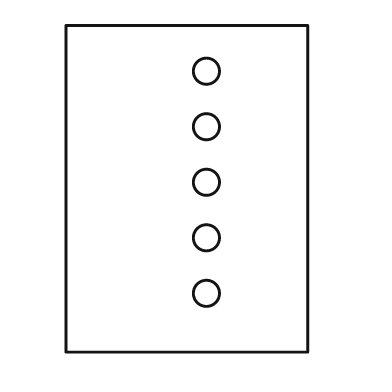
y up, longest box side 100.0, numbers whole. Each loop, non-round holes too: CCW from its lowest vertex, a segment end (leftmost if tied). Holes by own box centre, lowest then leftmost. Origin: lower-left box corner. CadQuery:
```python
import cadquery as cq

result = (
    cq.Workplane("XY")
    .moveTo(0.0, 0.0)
    .lineTo(74.0, 0.0)
    .lineTo(74.0, 100.0)
    .lineTo(0.0, 100.0)
    .close()
    .moveTo(43.0, 18.0)
    .circle(4.0)
    .moveTo(43.0, 35.0)
    .circle(4.0)
    .moveTo(43.0, 52.0)
    .circle(4.0)
    .moveTo(43.0, 69.0)
    .circle(4.0)
    .moveTo(43.0, 86.0)
    .circle(4.0)
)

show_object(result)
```